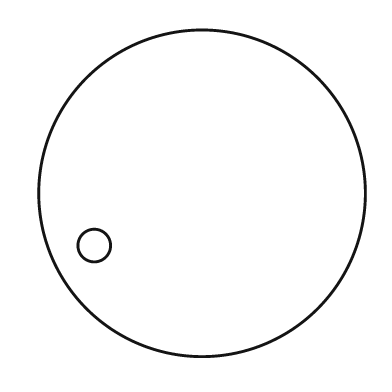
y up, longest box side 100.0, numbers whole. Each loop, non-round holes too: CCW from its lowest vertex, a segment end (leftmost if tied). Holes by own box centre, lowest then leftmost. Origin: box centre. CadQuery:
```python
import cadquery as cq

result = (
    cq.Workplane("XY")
    .moveTo(0.0, 0.0)
    .circle(50.0)
    .moveTo(-33.0, -16.0)
    .circle(5.0)
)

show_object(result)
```